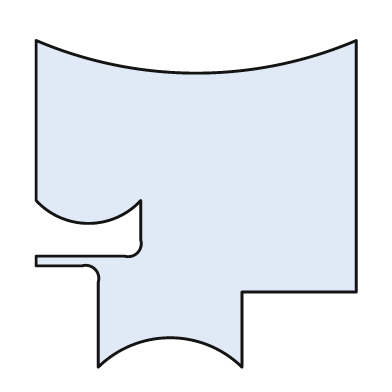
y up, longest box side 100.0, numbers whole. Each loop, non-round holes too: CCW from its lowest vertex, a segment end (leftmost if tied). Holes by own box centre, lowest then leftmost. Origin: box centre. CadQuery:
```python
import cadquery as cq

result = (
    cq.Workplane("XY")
    .moveTo(-30.0, -50.0)
    .threePointArc((-8.0, -41.0), (14.0, -50.0))
    .lineTo(14.0, -27.0)
    .lineTo(49.0, -27.0)
    .lineTo(49.0, 50.0)
    .threePointArc((0.0, 40.0), (-49.0, 50.0))
    .lineTo(-49.0, 1.0)
    .threePointArc((-33.0, -6.0), (-17.0, 1.0))
    .lineTo(-17.0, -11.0)
    .threePointArc((-18.0, -15.0), (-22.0, -16.0))
    .lineTo(-49.0, -16.0)
    .lineTo(-49.0, -19.0)
    .lineTo(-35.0, -19.0)
    .threePointArc((-31.0, -20.0), (-30.0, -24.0))
    .close()
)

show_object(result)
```